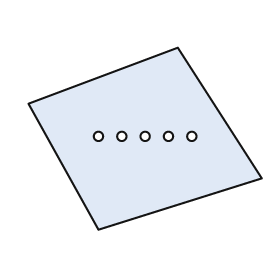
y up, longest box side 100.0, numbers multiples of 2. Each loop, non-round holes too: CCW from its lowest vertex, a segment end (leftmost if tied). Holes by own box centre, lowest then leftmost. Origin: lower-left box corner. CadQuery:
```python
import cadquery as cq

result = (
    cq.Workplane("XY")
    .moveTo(30.0, 0.0)
    .lineTo(100.0, 22.0)
    .lineTo(64.0, 78.0)
    .lineTo(0.0, 54.0)
    .close()
    .moveTo(30.0, 40.0)
    .circle(2.0)
    .moveTo(40.0, 40.0)
    .circle(2.0)
    .moveTo(50.0, 40.0)
    .circle(2.0)
    .moveTo(60.0, 40.0)
    .circle(2.0)
    .moveTo(70.0, 40.0)
    .circle(2.0)
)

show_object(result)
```